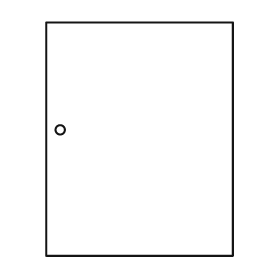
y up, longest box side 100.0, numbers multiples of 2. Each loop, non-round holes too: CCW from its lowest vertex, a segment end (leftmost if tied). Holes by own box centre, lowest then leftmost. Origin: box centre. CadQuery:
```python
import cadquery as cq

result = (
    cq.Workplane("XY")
    .moveTo(-40.0, -50.0)
    .lineTo(40.0, -50.0)
    .lineTo(40.0, 50.0)
    .lineTo(-40.0, 50.0)
    .close()
    .moveTo(-34.0, 4.0)
    .circle(2.0)
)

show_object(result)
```